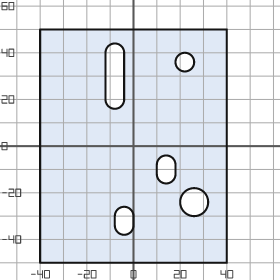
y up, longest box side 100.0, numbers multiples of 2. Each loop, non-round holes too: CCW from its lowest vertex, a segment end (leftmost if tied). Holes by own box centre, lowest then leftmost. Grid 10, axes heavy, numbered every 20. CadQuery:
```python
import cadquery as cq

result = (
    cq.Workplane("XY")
    .moveTo(-40.0, -50.0)
    .lineTo(40.0, -50.0)
    .lineTo(40.0, 50.0)
    .lineTo(-40.0, 50.0)
    .close()
    .moveTo(-8.0, -34.0)
    .threePointArc((-4.0, -38.0), (0.0, -34.0))
    .lineTo(0.0, -30.0)
    .threePointArc((-4.0, -26.0), (-8.0, -30.0))
    .close()
    .moveTo(26.0, -24.0)
    .circle(6.0)
    .moveTo(10.0, -12.0)
    .threePointArc((14.0, -16.0), (18.0, -12.0))
    .lineTo(18.0, -8.0)
    .threePointArc((14.0, -4.0), (10.0, -8.0))
    .close()
    .moveTo(-12.0, 20.0)
    .threePointArc((-8.0, 16.0), (-4.0, 20.0))
    .lineTo(-4.0, 40.0)
    .threePointArc((-8.0, 44.0), (-12.0, 40.0))
    .close()
    .moveTo(22.0, 36.0)
    .circle(4.0)
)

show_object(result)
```